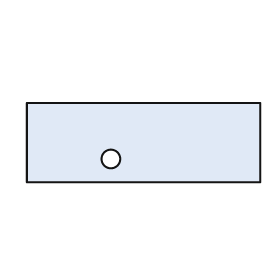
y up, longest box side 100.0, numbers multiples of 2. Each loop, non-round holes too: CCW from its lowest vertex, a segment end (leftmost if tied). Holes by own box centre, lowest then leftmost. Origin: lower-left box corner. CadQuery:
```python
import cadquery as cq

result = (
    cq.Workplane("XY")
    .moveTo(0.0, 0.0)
    .lineTo(100.0, 0.0)
    .lineTo(100.0, 34.0)
    .lineTo(0.0, 34.0)
    .close()
    .moveTo(36.0, 10.0)
    .circle(4.0)
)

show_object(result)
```